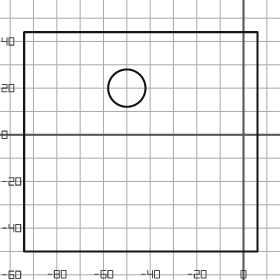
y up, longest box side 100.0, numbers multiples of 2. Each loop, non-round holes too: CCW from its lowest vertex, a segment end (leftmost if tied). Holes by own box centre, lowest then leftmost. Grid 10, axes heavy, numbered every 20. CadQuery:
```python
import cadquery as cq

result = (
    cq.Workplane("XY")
    .moveTo(-94.0, -50.0)
    .lineTo(6.0, -50.0)
    .lineTo(6.0, 44.0)
    .lineTo(-94.0, 44.0)
    .close()
    .moveTo(-50.0, 20.0)
    .circle(8.0)
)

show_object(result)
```